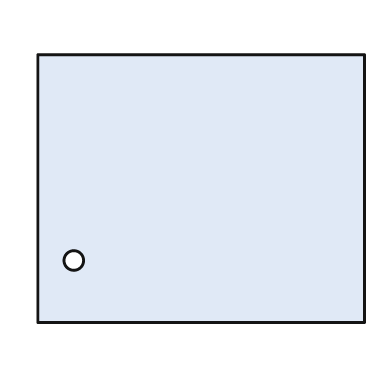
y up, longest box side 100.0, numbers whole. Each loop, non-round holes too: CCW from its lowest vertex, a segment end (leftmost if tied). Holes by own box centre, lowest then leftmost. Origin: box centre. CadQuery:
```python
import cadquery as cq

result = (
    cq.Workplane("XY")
    .moveTo(-50.0, -41.0)
    .lineTo(50.0, -41.0)
    .lineTo(50.0, 41.0)
    .lineTo(-50.0, 41.0)
    .close()
    .moveTo(-39.0, -22.0)
    .circle(3.0)
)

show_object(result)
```